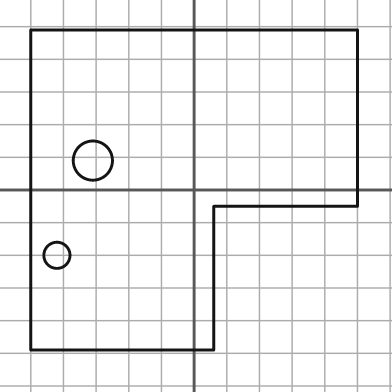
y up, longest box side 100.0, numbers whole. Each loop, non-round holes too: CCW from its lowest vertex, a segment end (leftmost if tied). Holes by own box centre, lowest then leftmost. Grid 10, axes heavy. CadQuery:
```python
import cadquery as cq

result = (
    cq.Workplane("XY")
    .moveTo(-50.0, -49.0)
    .lineTo(6.0, -49.0)
    .lineTo(6.0, -5.0)
    .lineTo(50.0, -5.0)
    .lineTo(50.0, 49.0)
    .lineTo(-50.0, 49.0)
    .close()
    .moveTo(-42.0, -20.0)
    .circle(4.0)
    .moveTo(-31.0, 9.0)
    .circle(6.0)
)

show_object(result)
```